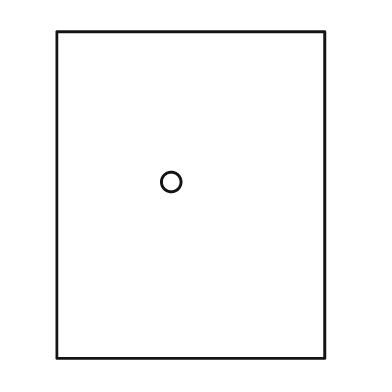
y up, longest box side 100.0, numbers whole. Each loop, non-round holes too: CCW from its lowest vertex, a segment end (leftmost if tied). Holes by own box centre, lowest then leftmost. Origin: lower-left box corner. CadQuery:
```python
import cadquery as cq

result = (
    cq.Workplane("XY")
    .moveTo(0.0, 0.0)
    .lineTo(82.0, 0.0)
    .lineTo(82.0, 100.0)
    .lineTo(0.0, 100.0)
    .close()
    .moveTo(35.0, 54.0)
    .circle(3.0)
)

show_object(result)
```